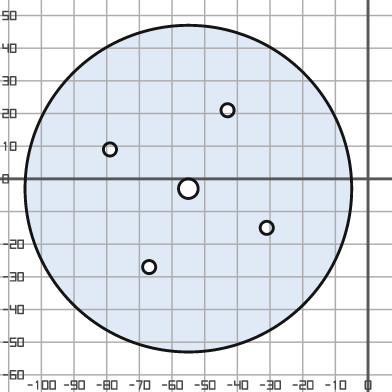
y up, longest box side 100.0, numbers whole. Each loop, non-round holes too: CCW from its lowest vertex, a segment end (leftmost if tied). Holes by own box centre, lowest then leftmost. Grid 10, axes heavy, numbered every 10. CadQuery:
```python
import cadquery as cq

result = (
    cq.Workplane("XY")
    .moveTo(-55.0, -3.0)
    .circle(50.0)
    .moveTo(-67.0, -27.0)
    .circle(2.0)
    .moveTo(-31.0, -15.0)
    .circle(2.0)
    .moveTo(-55.0, -3.0)
    .circle(3.0)
    .moveTo(-79.0, 9.0)
    .circle(2.0)
    .moveTo(-43.0, 21.0)
    .circle(2.0)
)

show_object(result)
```